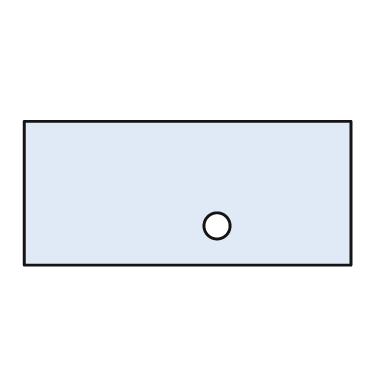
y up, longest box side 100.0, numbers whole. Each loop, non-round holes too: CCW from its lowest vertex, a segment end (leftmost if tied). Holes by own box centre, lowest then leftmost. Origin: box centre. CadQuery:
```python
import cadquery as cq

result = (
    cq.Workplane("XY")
    .moveTo(-50.0, -22.0)
    .lineTo(50.0, -22.0)
    .lineTo(50.0, 22.0)
    .lineTo(-50.0, 22.0)
    .close()
    .moveTo(9.0, -10.0)
    .circle(4.0)
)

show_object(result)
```